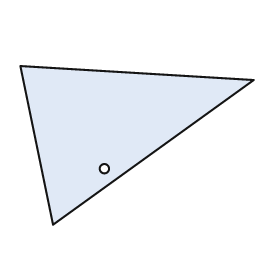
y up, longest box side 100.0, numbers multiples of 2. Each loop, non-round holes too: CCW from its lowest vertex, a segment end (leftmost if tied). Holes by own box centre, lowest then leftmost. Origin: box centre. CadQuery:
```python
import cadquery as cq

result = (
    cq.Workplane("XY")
    .moveTo(-36.0, -34.0)
    .lineTo(50.0, 28.0)
    .lineTo(-50.0, 34.0)
    .close()
    .moveTo(-14.0, -10.0)
    .circle(2.0)
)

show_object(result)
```